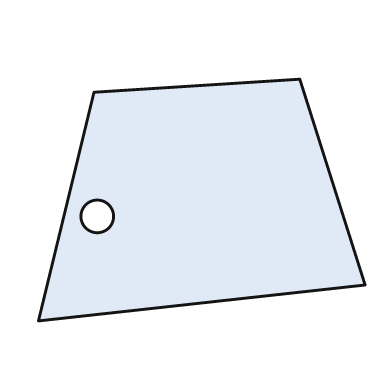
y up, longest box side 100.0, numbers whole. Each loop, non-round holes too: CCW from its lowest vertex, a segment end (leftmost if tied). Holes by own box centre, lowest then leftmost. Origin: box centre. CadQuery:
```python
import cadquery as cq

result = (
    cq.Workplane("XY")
    .moveTo(-50.0, -37.0)
    .lineTo(50.0, -26.0)
    .lineTo(30.0, 37.0)
    .lineTo(-33.0, 33.0)
    .close()
    .moveTo(-32.0, -5.0)
    .circle(5.0)
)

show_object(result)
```